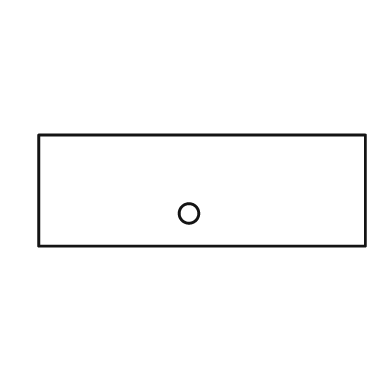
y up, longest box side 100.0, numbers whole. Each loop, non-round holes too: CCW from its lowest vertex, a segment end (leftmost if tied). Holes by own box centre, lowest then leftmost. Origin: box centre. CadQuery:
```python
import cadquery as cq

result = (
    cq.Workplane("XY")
    .moveTo(-50.0, -17.0)
    .lineTo(50.0, -17.0)
    .lineTo(50.0, 17.0)
    .lineTo(-50.0, 17.0)
    .close()
    .moveTo(-4.0, -7.0)
    .circle(3.0)
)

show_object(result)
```